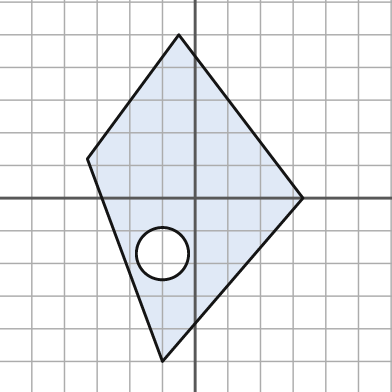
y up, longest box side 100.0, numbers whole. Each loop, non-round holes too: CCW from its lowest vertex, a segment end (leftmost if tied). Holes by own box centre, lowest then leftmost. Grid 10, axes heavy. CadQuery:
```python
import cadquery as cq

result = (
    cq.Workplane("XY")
    .moveTo(-10.0, -50.0)
    .lineTo(33.0, 0.0)
    .lineTo(-5.0, 50.0)
    .lineTo(-33.0, 12.0)
    .close()
    .moveTo(-10.0, -17.0)
    .circle(8.0)
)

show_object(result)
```